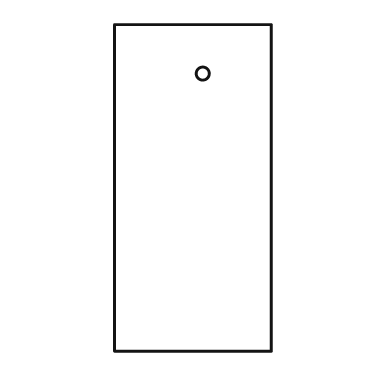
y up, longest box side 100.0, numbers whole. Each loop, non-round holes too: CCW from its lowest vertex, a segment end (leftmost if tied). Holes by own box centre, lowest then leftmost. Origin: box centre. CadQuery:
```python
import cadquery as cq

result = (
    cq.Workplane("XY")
    .moveTo(-24.0, -50.0)
    .lineTo(24.0, -50.0)
    .lineTo(24.0, 50.0)
    .lineTo(-24.0, 50.0)
    .close()
    .moveTo(3.0, 35.0)
    .circle(2.0)
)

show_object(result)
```